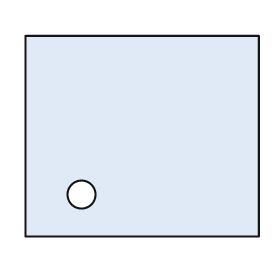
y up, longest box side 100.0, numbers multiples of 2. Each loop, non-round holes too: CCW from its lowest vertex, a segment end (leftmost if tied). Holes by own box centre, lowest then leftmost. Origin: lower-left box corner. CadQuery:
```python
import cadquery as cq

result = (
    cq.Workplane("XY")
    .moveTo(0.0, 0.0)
    .lineTo(100.0, 0.0)
    .lineTo(100.0, 86.0)
    .lineTo(0.0, 86.0)
    .close()
    .moveTo(24.0, 18.0)
    .circle(6.0)
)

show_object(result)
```